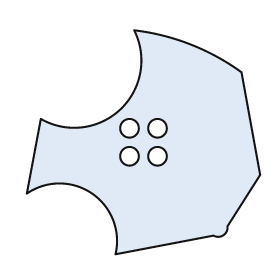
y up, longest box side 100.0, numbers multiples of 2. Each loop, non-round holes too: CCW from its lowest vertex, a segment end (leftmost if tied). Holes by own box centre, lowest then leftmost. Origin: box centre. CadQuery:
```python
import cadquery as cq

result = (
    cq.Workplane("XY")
    .moveTo(-12.0, -48.0)
    .lineTo(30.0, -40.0)
    .threePointArc((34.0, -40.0), (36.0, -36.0))
    .lineTo(50.0, -14.0)
    .lineTo(42.0, 30.0)
    .threePointArc((20.0, 42.0), (-4.0, 48.0))
    .threePointArc((-10.0, 14.0), (-44.0, 10.0))
    .lineTo(-50.0, -22.0)
    .threePointArc((-22.0, -22.0), (-12.0, -48.0))
    .close()
    .moveTo(-6.0, -6.0)
    .circle(4.0)
    .moveTo(6.0, -6.0)
    .circle(4.0)
    .moveTo(-6.0, 6.0)
    .circle(4.0)
    .moveTo(6.0, 6.0)
    .circle(4.0)
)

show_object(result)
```